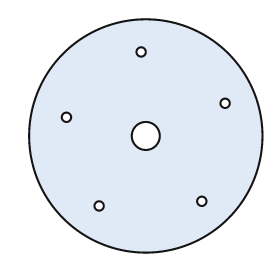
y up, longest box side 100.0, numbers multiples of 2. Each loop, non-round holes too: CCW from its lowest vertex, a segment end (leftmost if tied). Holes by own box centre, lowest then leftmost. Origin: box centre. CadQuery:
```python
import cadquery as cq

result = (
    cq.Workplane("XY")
    .moveTo(0.0, 0.0)
    .circle(50.0)
    .moveTo(-20.0, -30.0)
    .circle(2.0)
    .moveTo(24.0, -28.0)
    .circle(2.0)
    .moveTo(0.0, 0.0)
    .circle(6.0)
    .moveTo(-34.0, 8.0)
    .circle(2.0)
    .moveTo(34.0, 14.0)
    .circle(2.0)
    .moveTo(-2.0, 36.0)
    .circle(2.0)
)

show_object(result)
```